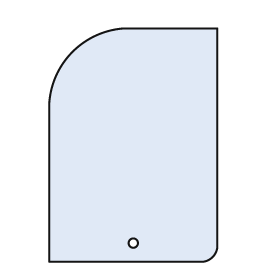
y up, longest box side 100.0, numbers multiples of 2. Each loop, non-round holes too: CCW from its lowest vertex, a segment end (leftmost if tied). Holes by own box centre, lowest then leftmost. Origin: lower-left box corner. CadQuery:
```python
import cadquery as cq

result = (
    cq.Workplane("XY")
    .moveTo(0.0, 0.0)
    .lineTo(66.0, 0.0)
    .threePointArc((70.0, 2.0), (72.0, 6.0))
    .lineTo(72.0, 100.0)
    .lineTo(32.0, 100.0)
    .threePointArc((10.0, 90.0), (0.0, 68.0))
    .close()
    .moveTo(36.0, 8.0)
    .circle(2.0)
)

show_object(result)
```